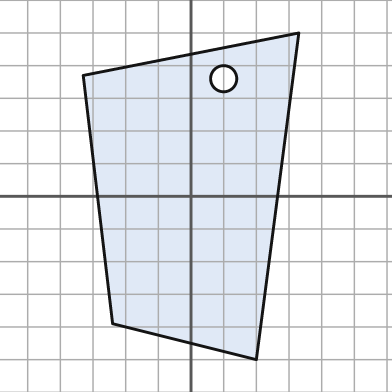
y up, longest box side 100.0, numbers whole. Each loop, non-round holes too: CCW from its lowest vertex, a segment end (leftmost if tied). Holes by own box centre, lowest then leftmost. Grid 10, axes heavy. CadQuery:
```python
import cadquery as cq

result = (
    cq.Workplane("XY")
    .moveTo(20.0, -50.0)
    .lineTo(33.0, 50.0)
    .lineTo(-33.0, 37.0)
    .lineTo(-24.0, -39.0)
    .close()
    .moveTo(10.0, 36.0)
    .circle(4.0)
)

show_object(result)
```